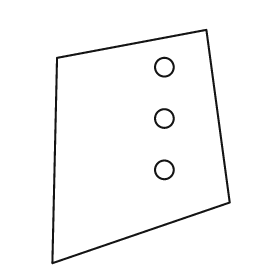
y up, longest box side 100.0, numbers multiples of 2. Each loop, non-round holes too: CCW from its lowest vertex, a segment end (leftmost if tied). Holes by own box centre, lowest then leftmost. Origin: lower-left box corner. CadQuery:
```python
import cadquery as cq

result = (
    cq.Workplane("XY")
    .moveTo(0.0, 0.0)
    .lineTo(76.0, 26.0)
    .lineTo(66.0, 100.0)
    .lineTo(2.0, 88.0)
    .close()
    .moveTo(48.0, 40.0)
    .circle(4.0)
    .moveTo(48.0, 62.0)
    .circle(4.0)
    .moveTo(48.0, 84.0)
    .circle(4.0)
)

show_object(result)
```